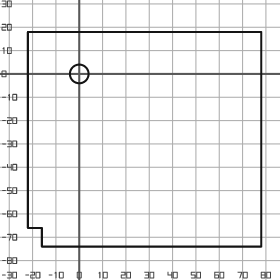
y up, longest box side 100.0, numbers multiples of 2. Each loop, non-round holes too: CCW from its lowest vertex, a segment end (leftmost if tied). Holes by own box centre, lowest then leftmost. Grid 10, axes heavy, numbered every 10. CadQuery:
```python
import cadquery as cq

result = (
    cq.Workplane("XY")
    .moveTo(-16.0, -74.0)
    .lineTo(78.0, -74.0)
    .lineTo(78.0, 18.0)
    .lineTo(-22.0, 18.0)
    .lineTo(-22.0, -66.0)
    .lineTo(-16.0, -66.0)
    .close()
    .moveTo(0.0, 0.0)
    .circle(4.0)
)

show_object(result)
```